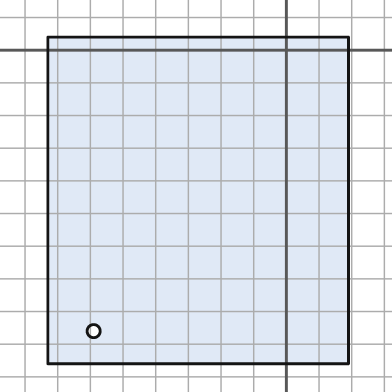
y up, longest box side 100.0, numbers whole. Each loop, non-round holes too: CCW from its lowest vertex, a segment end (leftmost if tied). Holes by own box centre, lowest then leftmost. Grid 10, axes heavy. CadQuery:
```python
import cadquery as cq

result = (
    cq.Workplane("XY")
    .moveTo(-73.0, -96.0)
    .lineTo(19.0, -96.0)
    .lineTo(19.0, 4.0)
    .lineTo(-73.0, 4.0)
    .close()
    .moveTo(-59.0, -86.0)
    .circle(2.0)
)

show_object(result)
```